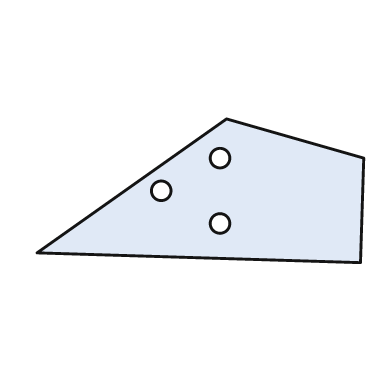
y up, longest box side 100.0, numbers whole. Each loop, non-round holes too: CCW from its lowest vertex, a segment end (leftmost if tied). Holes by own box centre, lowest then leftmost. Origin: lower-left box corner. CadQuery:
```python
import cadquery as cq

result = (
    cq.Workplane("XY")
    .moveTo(99.0, 0.0)
    .lineTo(100.0, 32.0)
    .lineTo(58.0, 44.0)
    .lineTo(0.0, 3.0)
    .close()
    .moveTo(56.0, 12.0)
    .circle(3.0)
    .moveTo(38.0, 22.0)
    .circle(3.0)
    .moveTo(56.0, 32.0)
    .circle(3.0)
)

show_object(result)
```